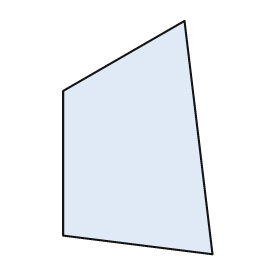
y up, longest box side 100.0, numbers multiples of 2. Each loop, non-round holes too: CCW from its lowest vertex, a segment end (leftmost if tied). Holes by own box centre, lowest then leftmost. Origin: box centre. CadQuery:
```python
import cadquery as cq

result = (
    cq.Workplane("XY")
    .moveTo(32.0, -50.0)
    .lineTo(20.0, 50.0)
    .lineTo(-32.0, 20.0)
    .lineTo(-32.0, -42.0)
    .close()
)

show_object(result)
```